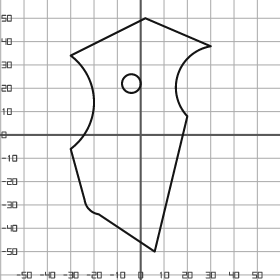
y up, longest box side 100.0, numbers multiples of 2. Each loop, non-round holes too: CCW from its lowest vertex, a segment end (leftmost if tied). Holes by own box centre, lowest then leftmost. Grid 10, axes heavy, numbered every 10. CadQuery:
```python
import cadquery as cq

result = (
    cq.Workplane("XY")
    .moveTo(6.0, -50.0)
    .lineTo(20.0, 8.0)
    .threePointArc((16.0, 26.0), (30.0, 38.0))
    .lineTo(2.0, 50.0)
    .lineTo(-30.0, 34.0)
    .threePointArc((-20.0, 14.0), (-30.0, -6.0))
    .lineTo(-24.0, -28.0)
    .threePointArc((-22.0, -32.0), (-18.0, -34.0))
    .close()
    .moveTo(-4.0, 22.0)
    .circle(4.0)
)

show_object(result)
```